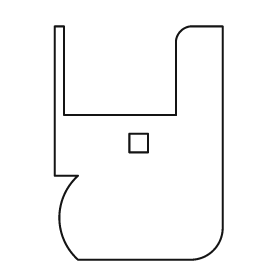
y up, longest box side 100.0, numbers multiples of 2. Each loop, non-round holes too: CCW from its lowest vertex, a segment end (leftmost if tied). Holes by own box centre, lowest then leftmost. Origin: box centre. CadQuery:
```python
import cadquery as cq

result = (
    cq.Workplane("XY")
    .moveTo(-26.0, -50.0)
    .lineTo(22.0, -50.0)
    .threePointArc((32.0, -46.0), (36.0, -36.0))
    .lineTo(36.0, 50.0)
    .lineTo(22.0, 50.0)
    .threePointArc((18.0, 48.0), (16.0, 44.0))
    .lineTo(16.0, 12.0)
    .lineTo(-32.0, 12.0)
    .lineTo(-32.0, 50.0)
    .lineTo(-36.0, 50.0)
    .lineTo(-36.0, -14.0)
    .lineTo(-26.0, -14.0)
    .threePointArc((-34.0, -32.0), (-26.0, -50.0))
    .close()
    .moveTo(-4.0, -4.0)
    .lineTo(4.0, -4.0)
    .lineTo(4.0, 4.0)
    .lineTo(-4.0, 4.0)
    .close()
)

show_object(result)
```